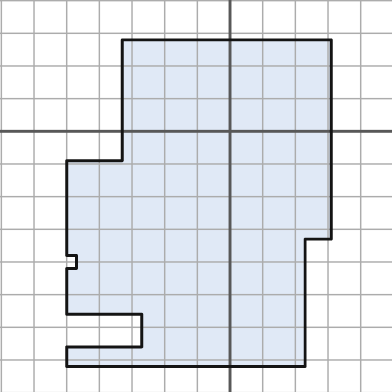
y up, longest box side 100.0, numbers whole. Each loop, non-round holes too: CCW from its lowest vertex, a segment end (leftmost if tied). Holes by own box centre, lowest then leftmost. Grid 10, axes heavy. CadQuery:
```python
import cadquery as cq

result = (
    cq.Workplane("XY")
    .moveTo(-50.0, -72.0)
    .lineTo(23.0, -72.0)
    .lineTo(23.0, -33.0)
    .lineTo(31.0, -33.0)
    .lineTo(31.0, 28.0)
    .lineTo(-33.0, 28.0)
    .lineTo(-33.0, -9.0)
    .lineTo(-50.0, -9.0)
    .lineTo(-50.0, -38.0)
    .lineTo(-47.0, -38.0)
    .lineTo(-47.0, -42.0)
    .lineTo(-50.0, -42.0)
    .lineTo(-50.0, -56.0)
    .lineTo(-27.0, -56.0)
    .lineTo(-27.0, -66.0)
    .lineTo(-50.0, -66.0)
    .close()
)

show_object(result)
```